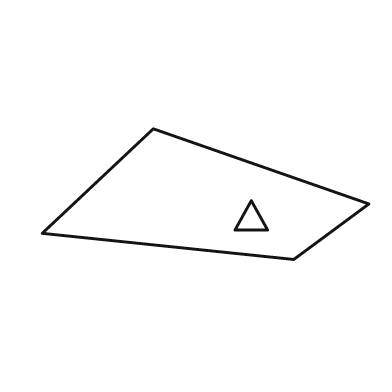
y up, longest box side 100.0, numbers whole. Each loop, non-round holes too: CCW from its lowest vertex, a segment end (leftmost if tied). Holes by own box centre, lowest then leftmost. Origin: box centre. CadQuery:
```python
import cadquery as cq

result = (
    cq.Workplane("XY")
    .moveTo(27.0, -20.0)
    .lineTo(50.0, -3.0)
    .lineTo(-16.0, 20.0)
    .lineTo(-50.0, -12.0)
    .close()
    .moveTo(9.0, -11.0)
    .lineTo(19.0, -11.0)
    .lineTo(14.0, -2.0)
    .close()
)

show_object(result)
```